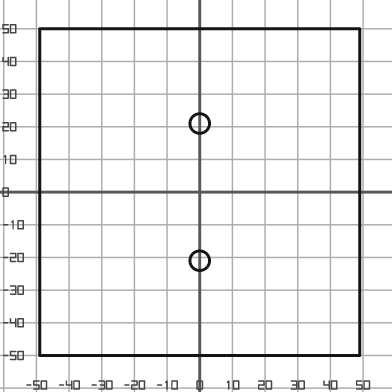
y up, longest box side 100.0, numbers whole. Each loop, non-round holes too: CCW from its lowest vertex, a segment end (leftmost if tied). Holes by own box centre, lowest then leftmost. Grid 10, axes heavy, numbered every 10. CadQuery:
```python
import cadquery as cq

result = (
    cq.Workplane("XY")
    .moveTo(-49.0, -50.0)
    .lineTo(49.0, -50.0)
    .lineTo(49.0, 50.0)
    .lineTo(-49.0, 50.0)
    .close()
    .moveTo(0.0, -21.0)
    .circle(3.0)
    .moveTo(0.0, 21.0)
    .circle(3.0)
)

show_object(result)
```